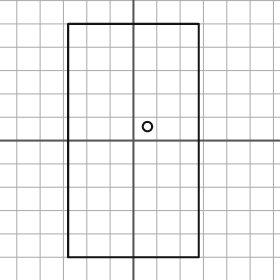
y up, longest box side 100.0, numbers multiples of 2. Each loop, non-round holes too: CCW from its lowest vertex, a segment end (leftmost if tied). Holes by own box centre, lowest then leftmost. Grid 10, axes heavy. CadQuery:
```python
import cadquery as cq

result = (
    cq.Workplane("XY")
    .moveTo(-28.0, -50.0)
    .lineTo(28.0, -50.0)
    .lineTo(28.0, 50.0)
    .lineTo(-28.0, 50.0)
    .close()
    .moveTo(6.0, 6.0)
    .circle(2.0)
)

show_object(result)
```